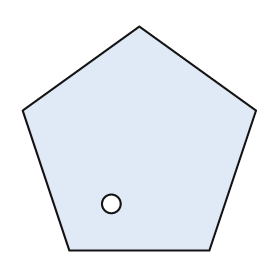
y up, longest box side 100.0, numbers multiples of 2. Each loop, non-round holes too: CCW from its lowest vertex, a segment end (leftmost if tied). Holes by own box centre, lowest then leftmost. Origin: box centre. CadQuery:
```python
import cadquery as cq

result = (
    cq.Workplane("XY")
    .moveTo(-30.0, -48.0)
    .lineTo(30.0, -48.0)
    .lineTo(50.0, 12.0)
    .lineTo(0.0, 48.0)
    .lineTo(-50.0, 12.0)
    .close()
    .moveTo(-12.0, -28.0)
    .circle(4.0)
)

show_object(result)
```